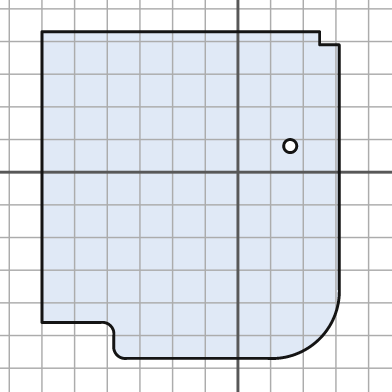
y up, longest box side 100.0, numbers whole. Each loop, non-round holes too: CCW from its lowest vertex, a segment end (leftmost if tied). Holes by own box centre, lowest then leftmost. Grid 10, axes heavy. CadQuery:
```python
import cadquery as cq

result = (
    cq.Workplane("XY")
    .moveTo(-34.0, -57.0)
    .lineTo(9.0, -57.0)
    .threePointArc((25.0, -51.0), (31.0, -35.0))
    .lineTo(31.0, 39.0)
    .lineTo(25.0, 39.0)
    .lineTo(25.0, 43.0)
    .lineTo(-60.0, 43.0)
    .lineTo(-60.0, -46.0)
    .lineTo(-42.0, -46.0)
    .threePointArc((-39.0, -47.0), (-38.0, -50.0))
    .lineTo(-38.0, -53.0)
    .threePointArc((-37.0, -56.0), (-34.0, -57.0))
    .close()
    .moveTo(16.0, 8.0)
    .circle(2.0)
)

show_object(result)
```